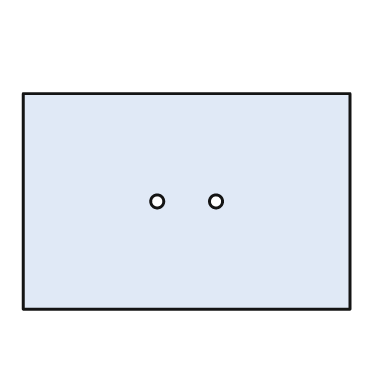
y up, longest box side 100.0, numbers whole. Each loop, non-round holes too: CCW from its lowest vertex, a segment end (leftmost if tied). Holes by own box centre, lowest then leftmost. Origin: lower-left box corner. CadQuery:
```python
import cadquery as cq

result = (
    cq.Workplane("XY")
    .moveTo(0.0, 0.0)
    .lineTo(100.0, 0.0)
    .lineTo(100.0, 66.0)
    .lineTo(0.0, 66.0)
    .close()
    .moveTo(41.0, 33.0)
    .circle(2.0)
    .moveTo(59.0, 33.0)
    .circle(2.0)
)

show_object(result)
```